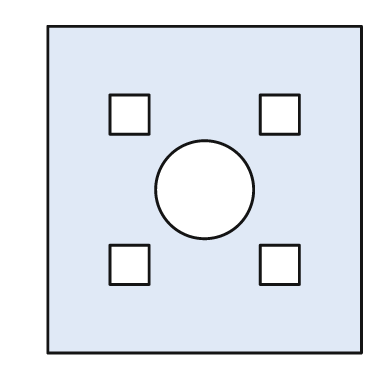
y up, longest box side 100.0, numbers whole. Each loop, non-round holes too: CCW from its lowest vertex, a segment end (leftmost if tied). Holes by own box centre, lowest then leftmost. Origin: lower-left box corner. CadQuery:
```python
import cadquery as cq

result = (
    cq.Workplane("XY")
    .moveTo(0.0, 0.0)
    .lineTo(96.0, 0.0)
    .lineTo(96.0, 100.0)
    .lineTo(0.0, 100.0)
    .close()
    .moveTo(19.0, 21.0)
    .lineTo(31.0, 21.0)
    .lineTo(31.0, 33.0)
    .lineTo(19.0, 33.0)
    .close()
    .moveTo(65.0, 21.0)
    .lineTo(77.0, 21.0)
    .lineTo(77.0, 33.0)
    .lineTo(65.0, 33.0)
    .close()
    .moveTo(48.0, 50.0)
    .circle(15.0)
    .moveTo(19.0, 67.0)
    .lineTo(31.0, 67.0)
    .lineTo(31.0, 79.0)
    .lineTo(19.0, 79.0)
    .close()
    .moveTo(65.0, 67.0)
    .lineTo(77.0, 67.0)
    .lineTo(77.0, 79.0)
    .lineTo(65.0, 79.0)
    .close()
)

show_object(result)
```